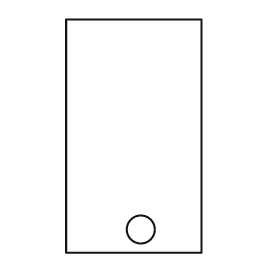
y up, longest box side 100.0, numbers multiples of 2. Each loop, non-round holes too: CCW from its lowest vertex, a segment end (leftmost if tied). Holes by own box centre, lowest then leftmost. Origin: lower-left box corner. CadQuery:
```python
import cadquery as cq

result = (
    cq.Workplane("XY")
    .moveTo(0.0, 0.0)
    .lineTo(58.0, 0.0)
    .lineTo(58.0, 100.0)
    .lineTo(0.0, 100.0)
    .close()
    .moveTo(32.0, 10.0)
    .circle(6.0)
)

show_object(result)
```